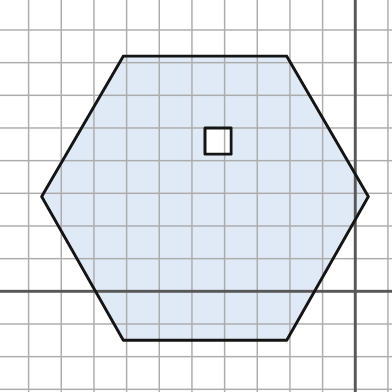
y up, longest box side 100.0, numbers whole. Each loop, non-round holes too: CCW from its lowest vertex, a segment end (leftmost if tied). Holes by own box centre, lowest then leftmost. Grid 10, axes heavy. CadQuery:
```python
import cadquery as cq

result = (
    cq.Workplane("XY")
    .moveTo(-71.0, -15.0)
    .lineTo(-21.0, -15.0)
    .lineTo(4.0, 29.0)
    .lineTo(-21.0, 72.0)
    .lineTo(-71.0, 72.0)
    .lineTo(-96.0, 29.0)
    .close()
    .moveTo(-46.0, 42.0)
    .lineTo(-38.0, 42.0)
    .lineTo(-38.0, 50.0)
    .lineTo(-46.0, 50.0)
    .close()
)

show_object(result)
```